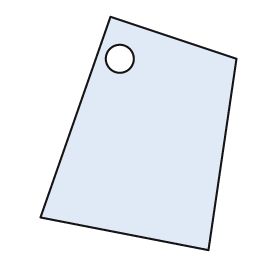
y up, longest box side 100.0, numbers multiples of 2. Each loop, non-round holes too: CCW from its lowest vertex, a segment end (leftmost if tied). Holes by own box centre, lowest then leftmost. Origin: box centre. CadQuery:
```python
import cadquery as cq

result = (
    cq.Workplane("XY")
    .moveTo(30.0, -50.0)
    .lineTo(42.0, 32.0)
    .lineTo(-12.0, 50.0)
    .lineTo(-42.0, -36.0)
    .close()
    .moveTo(-8.0, 32.0)
    .circle(6.0)
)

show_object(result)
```